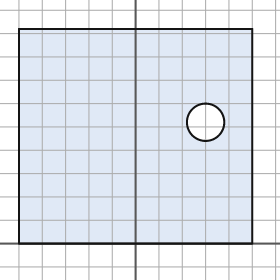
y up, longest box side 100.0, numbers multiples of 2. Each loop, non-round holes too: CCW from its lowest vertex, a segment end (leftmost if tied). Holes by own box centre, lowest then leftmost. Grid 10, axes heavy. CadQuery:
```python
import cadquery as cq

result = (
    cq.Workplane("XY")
    .moveTo(-50.0, 0.0)
    .lineTo(50.0, 0.0)
    .lineTo(50.0, 92.0)
    .lineTo(-50.0, 92.0)
    .close()
    .moveTo(30.0, 52.0)
    .circle(8.0)
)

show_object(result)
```